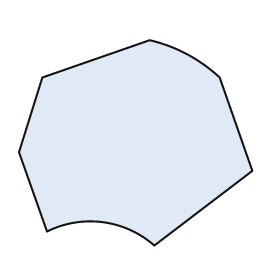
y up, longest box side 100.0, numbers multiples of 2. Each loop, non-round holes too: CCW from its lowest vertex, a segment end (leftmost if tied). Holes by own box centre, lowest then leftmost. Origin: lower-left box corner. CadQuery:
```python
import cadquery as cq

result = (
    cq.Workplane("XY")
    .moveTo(58.0, 0.0)
    .lineTo(100.0, 32.0)
    .lineTo(86.0, 72.0)
    .threePointArc((72.0, 82.0), (56.0, 88.0))
    .lineTo(10.0, 72.0)
    .lineTo(0.0, 40.0)
    .lineTo(12.0, 6.0)
    .threePointArc((36.0, 10.0), (58.0, 0.0))
    .close()
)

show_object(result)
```